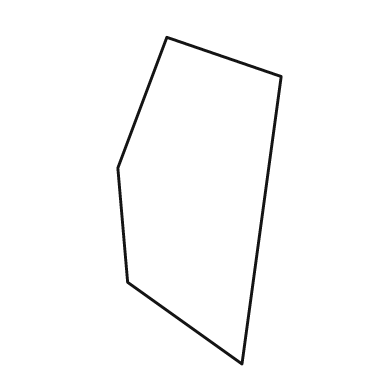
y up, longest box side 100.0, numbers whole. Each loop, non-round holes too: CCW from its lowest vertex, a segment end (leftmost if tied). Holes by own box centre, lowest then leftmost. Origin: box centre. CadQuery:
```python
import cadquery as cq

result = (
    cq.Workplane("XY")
    .moveTo(13.0, -50.0)
    .lineTo(25.0, 38.0)
    .lineTo(-10.0, 50.0)
    .lineTo(-25.0, 10.0)
    .lineTo(-22.0, -25.0)
    .close()
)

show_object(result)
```